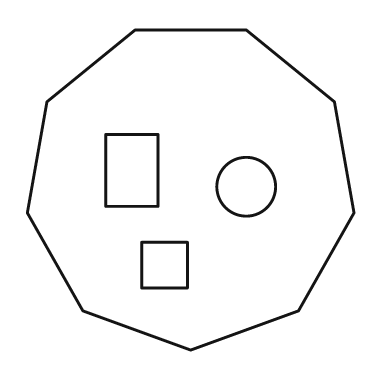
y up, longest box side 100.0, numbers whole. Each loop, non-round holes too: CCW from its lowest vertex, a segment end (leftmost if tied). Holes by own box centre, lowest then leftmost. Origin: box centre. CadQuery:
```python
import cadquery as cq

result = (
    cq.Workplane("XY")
    .moveTo(0.0, -49.0)
    .lineTo(33.0, -37.0)
    .lineTo(50.0, -7.0)
    .lineTo(44.0, 27.0)
    .lineTo(17.0, 49.0)
    .lineTo(-17.0, 49.0)
    .lineTo(-44.0, 27.0)
    .lineTo(-50.0, -7.0)
    .lineTo(-33.0, -37.0)
    .close()
    .moveTo(-15.0, -30.0)
    .lineTo(-1.0, -30.0)
    .lineTo(-1.0, -16.0)
    .lineTo(-15.0, -16.0)
    .close()
    .moveTo(17.0, 1.0)
    .circle(9.0)
    .moveTo(-26.0, -5.0)
    .lineTo(-10.0, -5.0)
    .lineTo(-10.0, 17.0)
    .lineTo(-26.0, 17.0)
    .close()
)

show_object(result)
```